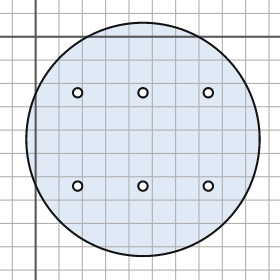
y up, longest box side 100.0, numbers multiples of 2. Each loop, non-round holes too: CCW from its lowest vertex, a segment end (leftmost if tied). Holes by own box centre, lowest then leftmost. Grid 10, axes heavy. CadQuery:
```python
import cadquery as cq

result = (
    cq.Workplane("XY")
    .moveTo(46.0, -44.0)
    .circle(50.0)
    .moveTo(18.0, -64.0)
    .circle(2.0)
    .moveTo(46.0, -64.0)
    .circle(2.0)
    .moveTo(74.0, -64.0)
    .circle(2.0)
    .moveTo(18.0, -24.0)
    .circle(2.0)
    .moveTo(46.0, -24.0)
    .circle(2.0)
    .moveTo(74.0, -24.0)
    .circle(2.0)
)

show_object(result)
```